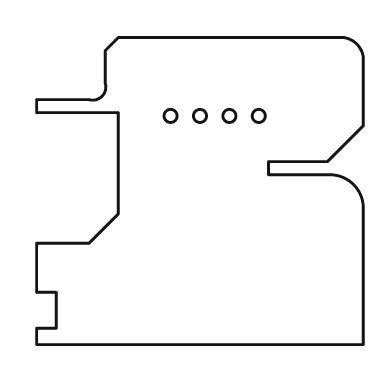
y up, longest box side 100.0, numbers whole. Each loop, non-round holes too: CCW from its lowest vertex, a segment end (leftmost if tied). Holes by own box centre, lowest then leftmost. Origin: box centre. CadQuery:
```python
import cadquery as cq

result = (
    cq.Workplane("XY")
    .moveTo(-50.0, -47.0)
    .lineTo(50.0, -47.0)
    .lineTo(50.0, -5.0)
    .threePointArc((47.0, 2.0), (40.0, 5.0))
    .lineTo(21.0, 5.0)
    .lineTo(21.0, 9.0)
    .lineTo(39.0, 9.0)
    .lineTo(50.0, 20.0)
    .lineTo(50.0, 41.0)
    .threePointArc((48.0, 45.0), (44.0, 47.0))
    .lineTo(-25.0, 47.0)
    .lineTo(-29.0, 43.0)
    .lineTo(-29.0, 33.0)
    .threePointArc((-30.0, 29.0), (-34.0, 28.0))
    .lineTo(-50.0, 28.0)
    .lineTo(-50.0, 24.0)
    .lineTo(-25.0, 24.0)
    .lineTo(-25.0, -7.0)
    .lineTo(-34.0, -16.0)
    .lineTo(-50.0, -16.0)
    .lineTo(-50.0, -31.0)
    .lineTo(-44.0, -31.0)
    .lineTo(-44.0, -42.0)
    .lineTo(-50.0, -42.0)
    .close()
    .moveTo(-9.0, 23.0)
    .circle(2.0)
    .moveTo(0.0, 23.0)
    .circle(2.0)
    .moveTo(9.0, 23.0)
    .circle(2.0)
    .moveTo(18.0, 23.0)
    .circle(2.0)
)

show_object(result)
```